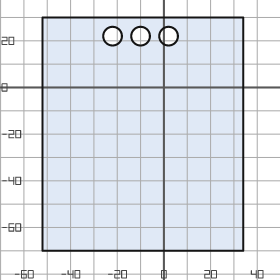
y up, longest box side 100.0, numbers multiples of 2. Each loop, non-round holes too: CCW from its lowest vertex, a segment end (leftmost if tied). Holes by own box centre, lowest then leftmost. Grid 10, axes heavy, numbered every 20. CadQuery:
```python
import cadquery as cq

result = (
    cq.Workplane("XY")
    .moveTo(-52.0, -70.0)
    .lineTo(34.0, -70.0)
    .lineTo(34.0, 30.0)
    .lineTo(-52.0, 30.0)
    .close()
    .moveTo(-22.0, 22.0)
    .circle(4.0)
    .moveTo(-10.0, 22.0)
    .circle(4.0)
    .moveTo(2.0, 22.0)
    .circle(4.0)
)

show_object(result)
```